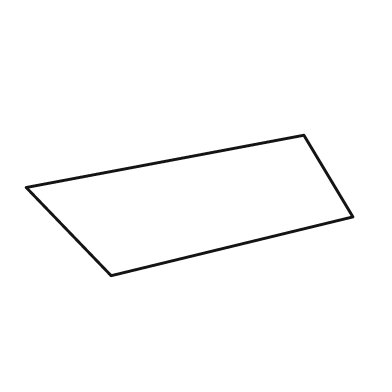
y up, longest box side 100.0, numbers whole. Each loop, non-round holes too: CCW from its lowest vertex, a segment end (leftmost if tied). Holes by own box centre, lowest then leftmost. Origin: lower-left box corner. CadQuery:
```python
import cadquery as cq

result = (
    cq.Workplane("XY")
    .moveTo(26.0, 0.0)
    .lineTo(100.0, 18.0)
    .lineTo(85.0, 43.0)
    .lineTo(0.0, 27.0)
    .close()
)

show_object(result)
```